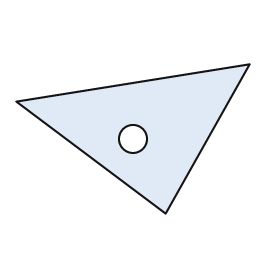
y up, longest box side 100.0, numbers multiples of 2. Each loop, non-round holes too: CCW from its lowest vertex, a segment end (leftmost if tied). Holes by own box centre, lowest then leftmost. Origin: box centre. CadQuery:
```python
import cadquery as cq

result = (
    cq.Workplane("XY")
    .moveTo(14.0, -32.0)
    .lineTo(50.0, 32.0)
    .lineTo(-50.0, 16.0)
    .close()
    .moveTo(0.0, 0.0)
    .circle(6.0)
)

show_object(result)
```